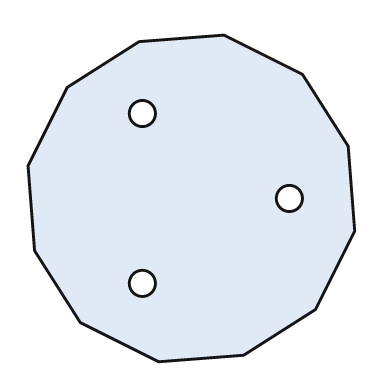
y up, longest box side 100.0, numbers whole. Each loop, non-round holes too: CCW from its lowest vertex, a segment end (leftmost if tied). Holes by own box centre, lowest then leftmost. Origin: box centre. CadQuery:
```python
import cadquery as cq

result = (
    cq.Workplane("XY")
    .moveTo(-10.0, -50.0)
    .lineTo(16.0, -48.0)
    .lineTo(38.0, -34.0)
    .lineTo(50.0, -10.0)
    .lineTo(48.0, 16.0)
    .lineTo(34.0, 38.0)
    .lineTo(10.0, 50.0)
    .lineTo(-16.0, 48.0)
    .lineTo(-38.0, 34.0)
    .lineTo(-50.0, 10.0)
    .lineTo(-48.0, -16.0)
    .lineTo(-34.0, -38.0)
    .close()
    .moveTo(-15.0, -26.0)
    .circle(4.0)
    .moveTo(30.0, 0.0)
    .circle(4.0)
    .moveTo(-15.0, 26.0)
    .circle(4.0)
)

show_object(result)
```